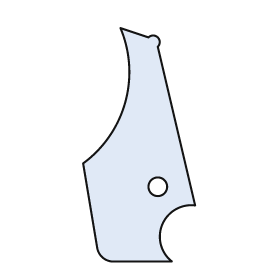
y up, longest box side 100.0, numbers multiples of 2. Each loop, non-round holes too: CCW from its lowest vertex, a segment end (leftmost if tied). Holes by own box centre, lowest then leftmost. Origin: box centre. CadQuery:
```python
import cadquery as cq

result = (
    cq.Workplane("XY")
    .moveTo(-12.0, -50.0)
    .lineTo(14.0, -50.0)
    .threePointArc((10.0, -34.0), (24.0, -26.0))
    .lineTo(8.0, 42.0)
    .threePointArc((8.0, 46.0), (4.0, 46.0))
    .lineTo(-8.0, 50.0)
    .threePointArc((-6.0, 18.0), (-24.0, -8.0))
    .lineTo(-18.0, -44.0)
    .threePointArc((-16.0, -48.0), (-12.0, -50.0))
    .close()
    .moveTo(8.0, -18.0)
    .circle(4.0)
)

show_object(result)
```